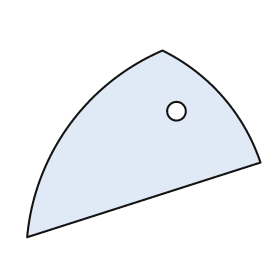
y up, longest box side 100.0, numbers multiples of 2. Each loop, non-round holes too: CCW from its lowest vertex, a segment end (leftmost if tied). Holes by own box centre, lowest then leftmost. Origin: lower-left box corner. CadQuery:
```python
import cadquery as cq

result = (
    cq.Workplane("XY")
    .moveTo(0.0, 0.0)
    .lineTo(100.0, 32.0)
    .threePointArc((84.0, 60.0), (58.0, 80.0))
    .threePointArc((18.0, 48.0), (0.0, 0.0))
    .close()
    .moveTo(64.0, 54.0)
    .circle(4.0)
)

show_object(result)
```